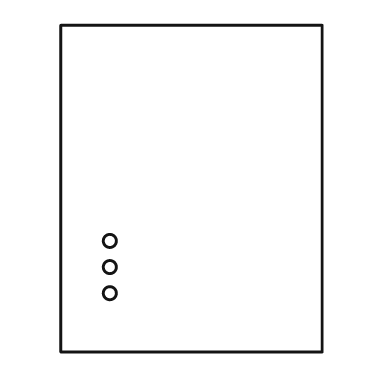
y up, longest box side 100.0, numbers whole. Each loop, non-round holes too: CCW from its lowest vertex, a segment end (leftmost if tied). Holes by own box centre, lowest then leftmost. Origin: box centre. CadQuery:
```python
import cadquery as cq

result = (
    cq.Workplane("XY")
    .moveTo(-40.0, -50.0)
    .lineTo(40.0, -50.0)
    .lineTo(40.0, 50.0)
    .lineTo(-40.0, 50.0)
    .close()
    .moveTo(-25.0, -32.0)
    .circle(2.0)
    .moveTo(-25.0, -24.0)
    .circle(2.0)
    .moveTo(-25.0, -16.0)
    .circle(2.0)
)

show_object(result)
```